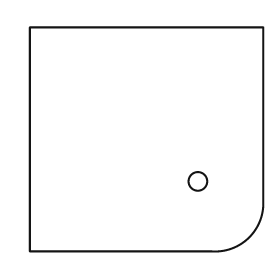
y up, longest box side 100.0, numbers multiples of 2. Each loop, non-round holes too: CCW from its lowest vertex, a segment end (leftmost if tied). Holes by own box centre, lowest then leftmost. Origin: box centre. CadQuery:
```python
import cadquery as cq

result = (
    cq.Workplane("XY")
    .moveTo(-50.0, -48.0)
    .lineTo(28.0, -48.0)
    .threePointArc((44.0, -42.0), (50.0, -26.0))
    .lineTo(50.0, 48.0)
    .lineTo(-50.0, 48.0)
    .close()
    .moveTo(22.0, -18.0)
    .circle(4.0)
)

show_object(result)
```